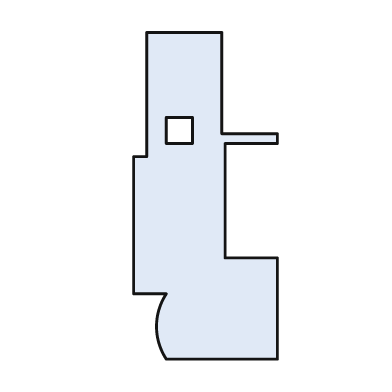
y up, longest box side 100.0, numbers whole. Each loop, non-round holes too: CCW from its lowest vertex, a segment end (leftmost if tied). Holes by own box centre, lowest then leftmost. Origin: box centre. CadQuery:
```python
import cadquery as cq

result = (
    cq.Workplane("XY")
    .moveTo(-12.0, -50.0)
    .lineTo(22.0, -50.0)
    .lineTo(22.0, -19.0)
    .lineTo(6.0, -19.0)
    .lineTo(6.0, 16.0)
    .lineTo(22.0, 16.0)
    .lineTo(22.0, 19.0)
    .lineTo(5.0, 19.0)
    .lineTo(5.0, 50.0)
    .lineTo(-18.0, 50.0)
    .lineTo(-18.0, 12.0)
    .lineTo(-22.0, 12.0)
    .lineTo(-22.0, -30.0)
    .lineTo(-12.0, -30.0)
    .threePointArc((-15.0, -40.0), (-12.0, -50.0))
    .close()
    .moveTo(-12.0, 16.0)
    .lineTo(-4.0, 16.0)
    .lineTo(-4.0, 24.0)
    .lineTo(-12.0, 24.0)
    .close()
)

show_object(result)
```